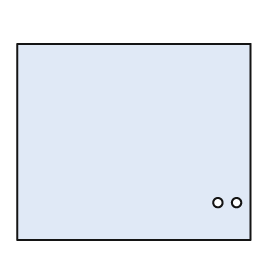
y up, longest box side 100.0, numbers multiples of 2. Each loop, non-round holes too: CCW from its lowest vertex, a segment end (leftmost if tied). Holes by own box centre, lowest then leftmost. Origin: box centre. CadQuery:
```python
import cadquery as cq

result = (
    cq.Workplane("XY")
    .moveTo(-50.0, -42.0)
    .lineTo(50.0, -42.0)
    .lineTo(50.0, 42.0)
    .lineTo(-50.0, 42.0)
    .close()
    .moveTo(36.0, -26.0)
    .circle(2.0)
    .moveTo(44.0, -26.0)
    .circle(2.0)
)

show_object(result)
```